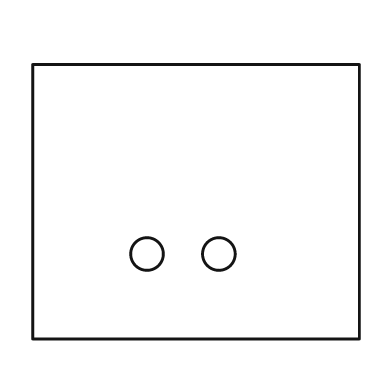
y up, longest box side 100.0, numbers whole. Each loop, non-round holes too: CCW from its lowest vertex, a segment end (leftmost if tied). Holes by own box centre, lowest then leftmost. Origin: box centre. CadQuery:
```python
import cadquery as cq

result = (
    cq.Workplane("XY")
    .moveTo(-50.0, -42.0)
    .lineTo(50.0, -42.0)
    .lineTo(50.0, 42.0)
    .lineTo(-50.0, 42.0)
    .close()
    .moveTo(-15.0, -16.0)
    .circle(5.0)
    .moveTo(7.0, -16.0)
    .circle(5.0)
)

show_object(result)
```